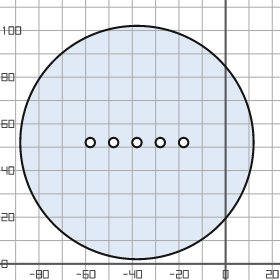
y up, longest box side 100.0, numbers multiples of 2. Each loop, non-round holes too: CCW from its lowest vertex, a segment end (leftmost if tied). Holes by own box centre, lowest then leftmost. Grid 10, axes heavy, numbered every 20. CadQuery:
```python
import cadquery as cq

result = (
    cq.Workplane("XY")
    .moveTo(-38.0, 52.0)
    .circle(50.0)
    .moveTo(-58.0, 52.0)
    .circle(2.0)
    .moveTo(-48.0, 52.0)
    .circle(2.0)
    .moveTo(-38.0, 52.0)
    .circle(2.0)
    .moveTo(-28.0, 52.0)
    .circle(2.0)
    .moveTo(-18.0, 52.0)
    .circle(2.0)
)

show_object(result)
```